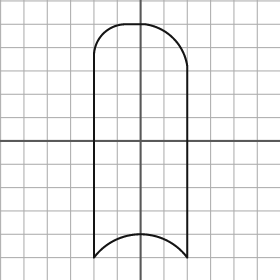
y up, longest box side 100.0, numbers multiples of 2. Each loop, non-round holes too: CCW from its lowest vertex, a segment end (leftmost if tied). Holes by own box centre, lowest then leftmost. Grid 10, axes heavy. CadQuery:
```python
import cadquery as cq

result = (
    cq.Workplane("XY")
    .moveTo(-20.0, -50.0)
    .threePointArc((0.0, -40.0), (20.0, -50.0))
    .lineTo(20.0, 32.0)
    .threePointArc((14.0, 44.0), (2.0, 50.0))
    .lineTo(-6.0, 50.0)
    .threePointArc((-16.0, 46.0), (-20.0, 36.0))
    .close()
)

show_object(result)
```